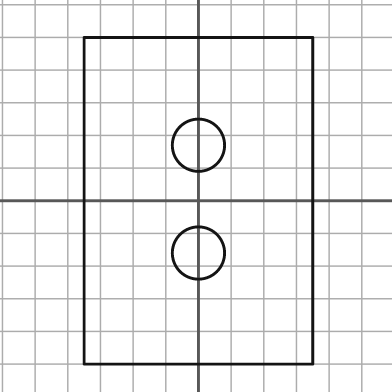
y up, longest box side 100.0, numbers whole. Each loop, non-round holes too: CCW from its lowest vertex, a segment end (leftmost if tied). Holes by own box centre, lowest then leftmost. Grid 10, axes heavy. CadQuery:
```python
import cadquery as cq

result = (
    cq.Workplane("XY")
    .moveTo(-35.0, -50.0)
    .lineTo(35.0, -50.0)
    .lineTo(35.0, 50.0)
    .lineTo(-35.0, 50.0)
    .close()
    .moveTo(0.0, -16.0)
    .circle(8.0)
    .moveTo(0.0, 17.0)
    .circle(8.0)
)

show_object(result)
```